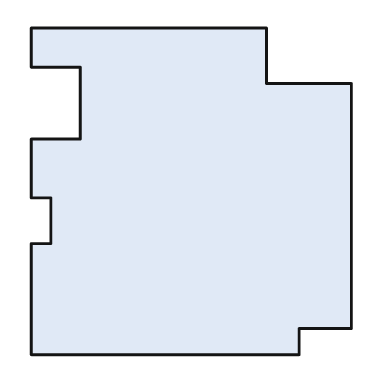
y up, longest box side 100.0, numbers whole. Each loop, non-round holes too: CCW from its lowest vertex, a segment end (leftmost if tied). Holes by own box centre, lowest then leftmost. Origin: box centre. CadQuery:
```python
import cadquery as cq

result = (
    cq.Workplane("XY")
    .moveTo(-49.0, -50.0)
    .lineTo(33.0, -50.0)
    .lineTo(33.0, -42.0)
    .lineTo(49.0, -42.0)
    .lineTo(49.0, 33.0)
    .lineTo(23.0, 33.0)
    .lineTo(23.0, 50.0)
    .lineTo(-49.0, 50.0)
    .lineTo(-49.0, 38.0)
    .lineTo(-34.0, 38.0)
    .lineTo(-34.0, 16.0)
    .lineTo(-49.0, 16.0)
    .lineTo(-49.0, -2.0)
    .lineTo(-43.0, -2.0)
    .lineTo(-43.0, -16.0)
    .lineTo(-49.0, -16.0)
    .close()
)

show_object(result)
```